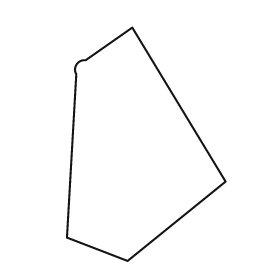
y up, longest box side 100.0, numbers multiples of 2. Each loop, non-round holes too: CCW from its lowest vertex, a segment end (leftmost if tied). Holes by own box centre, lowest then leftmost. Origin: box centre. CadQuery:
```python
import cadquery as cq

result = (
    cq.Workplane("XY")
    .moveTo(-8.0, -50.0)
    .lineTo(34.0, -16.0)
    .lineTo(-6.0, 50.0)
    .lineTo(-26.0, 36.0)
    .threePointArc((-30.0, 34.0), (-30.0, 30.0))
    .lineTo(-34.0, -40.0)
    .close()
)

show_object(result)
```